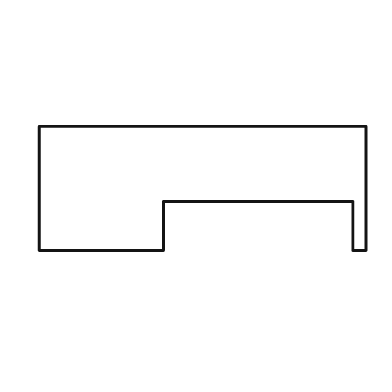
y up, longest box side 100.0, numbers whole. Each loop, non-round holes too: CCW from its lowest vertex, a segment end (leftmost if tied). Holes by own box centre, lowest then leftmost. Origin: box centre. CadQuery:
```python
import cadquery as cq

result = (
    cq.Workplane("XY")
    .moveTo(-50.0, -19.0)
    .lineTo(-12.0, -19.0)
    .lineTo(-12.0, -4.0)
    .lineTo(46.0, -4.0)
    .lineTo(46.0, -19.0)
    .lineTo(50.0, -19.0)
    .lineTo(50.0, 19.0)
    .lineTo(-50.0, 19.0)
    .close()
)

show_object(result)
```